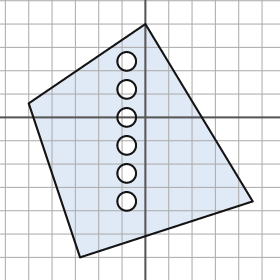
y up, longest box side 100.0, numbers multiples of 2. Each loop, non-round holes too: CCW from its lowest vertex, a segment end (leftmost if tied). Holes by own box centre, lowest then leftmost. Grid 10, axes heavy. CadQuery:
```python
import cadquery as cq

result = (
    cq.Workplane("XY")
    .moveTo(-28.0, -60.0)
    .lineTo(46.0, -36.0)
    .lineTo(0.0, 40.0)
    .lineTo(-50.0, 6.0)
    .close()
    .moveTo(-8.0, -36.0)
    .circle(4.0)
    .moveTo(-8.0, -24.0)
    .circle(4.0)
    .moveTo(-8.0, -12.0)
    .circle(4.0)
    .moveTo(-8.0, 0.0)
    .circle(4.0)
    .moveTo(-8.0, 12.0)
    .circle(4.0)
    .moveTo(-8.0, 24.0)
    .circle(4.0)
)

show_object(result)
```